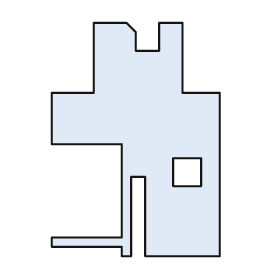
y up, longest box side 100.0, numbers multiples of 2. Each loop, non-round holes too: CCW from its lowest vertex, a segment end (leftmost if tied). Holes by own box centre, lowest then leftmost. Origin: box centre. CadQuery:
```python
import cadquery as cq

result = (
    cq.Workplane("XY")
    .moveTo(-6.0, -50.0)
    .lineTo(-2.0, -50.0)
    .lineTo(-2.0, -16.0)
    .lineTo(4.0, -16.0)
    .lineTo(4.0, -50.0)
    .lineTo(36.0, -50.0)
    .lineTo(36.0, 20.0)
    .lineTo(20.0, 20.0)
    .lineTo(20.0, 50.0)
    .lineTo(10.0, 50.0)
    .lineTo(10.0, 38.0)
    .lineTo(0.0, 38.0)
    .lineTo(0.0, 46.0)
    .lineTo(-4.0, 50.0)
    .lineTo(-18.0, 50.0)
    .lineTo(-18.0, 20.0)
    .lineTo(-36.0, 20.0)
    .lineTo(-36.0, -2.0)
    .lineTo(-6.0, -2.0)
    .lineTo(-6.0, -42.0)
    .lineTo(-36.0, -42.0)
    .lineTo(-36.0, -46.0)
    .lineTo(-6.0, -46.0)
    .close()
    .moveTo(16.0, -20.0)
    .lineTo(28.0, -20.0)
    .lineTo(28.0, -8.0)
    .lineTo(16.0, -8.0)
    .close()
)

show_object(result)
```